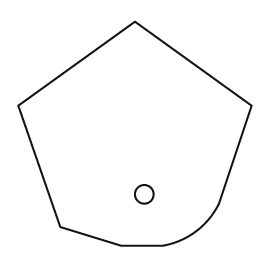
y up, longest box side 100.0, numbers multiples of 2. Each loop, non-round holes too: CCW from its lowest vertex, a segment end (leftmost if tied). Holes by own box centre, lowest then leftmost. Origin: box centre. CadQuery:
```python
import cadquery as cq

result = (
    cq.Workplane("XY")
    .moveTo(-6.0, -48.0)
    .lineTo(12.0, -48.0)
    .threePointArc((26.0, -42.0), (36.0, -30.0))
    .lineTo(50.0, 12.0)
    .lineTo(0.0, 48.0)
    .lineTo(-50.0, 12.0)
    .lineTo(-32.0, -40.0)
    .close()
    .moveTo(4.0, -26.0)
    .circle(4.0)
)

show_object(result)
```